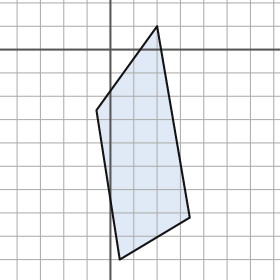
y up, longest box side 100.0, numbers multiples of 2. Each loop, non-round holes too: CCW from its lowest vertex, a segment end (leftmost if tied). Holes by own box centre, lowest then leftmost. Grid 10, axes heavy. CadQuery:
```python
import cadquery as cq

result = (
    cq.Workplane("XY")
    .moveTo(4.0, -90.0)
    .lineTo(34.0, -72.0)
    .lineTo(20.0, 10.0)
    .lineTo(-6.0, -26.0)
    .close()
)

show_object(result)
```